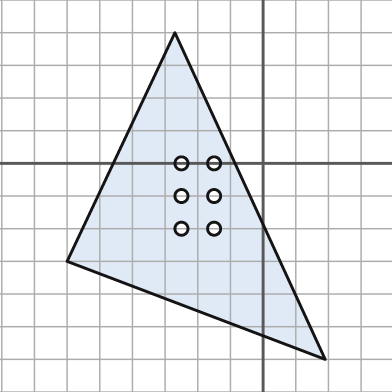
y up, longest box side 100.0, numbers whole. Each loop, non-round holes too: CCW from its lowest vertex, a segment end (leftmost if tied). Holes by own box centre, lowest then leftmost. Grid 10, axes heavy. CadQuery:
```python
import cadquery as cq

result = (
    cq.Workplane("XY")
    .moveTo(19.0, -60.0)
    .lineTo(-27.0, 40.0)
    .lineTo(-60.0, -30.0)
    .close()
    .moveTo(-25.0, -20.0)
    .circle(2.0)
    .moveTo(-15.0, -20.0)
    .circle(2.0)
    .moveTo(-25.0, -10.0)
    .circle(2.0)
    .moveTo(-15.0, -10.0)
    .circle(2.0)
    .moveTo(-25.0, 0.0)
    .circle(2.0)
    .moveTo(-15.0, 0.0)
    .circle(2.0)
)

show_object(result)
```